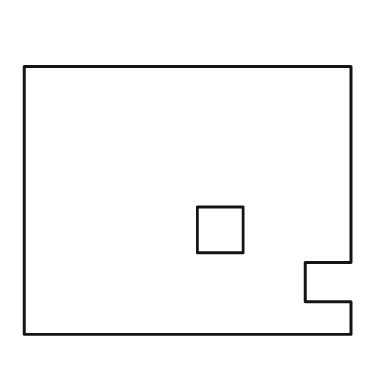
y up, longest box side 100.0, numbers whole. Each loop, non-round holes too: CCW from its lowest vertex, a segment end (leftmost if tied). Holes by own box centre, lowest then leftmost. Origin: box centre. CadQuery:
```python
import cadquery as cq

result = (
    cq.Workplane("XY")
    .moveTo(-50.0, -41.0)
    .lineTo(50.0, -41.0)
    .lineTo(50.0, -31.0)
    .lineTo(36.0, -31.0)
    .lineTo(36.0, -19.0)
    .lineTo(50.0, -19.0)
    .lineTo(50.0, 41.0)
    .lineTo(-50.0, 41.0)
    .close()
    .moveTo(3.0, -16.0)
    .lineTo(17.0, -16.0)
    .lineTo(17.0, -2.0)
    .lineTo(3.0, -2.0)
    .close()
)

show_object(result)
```